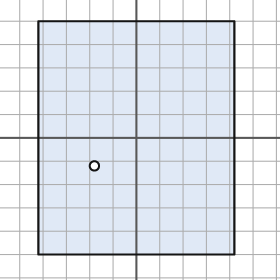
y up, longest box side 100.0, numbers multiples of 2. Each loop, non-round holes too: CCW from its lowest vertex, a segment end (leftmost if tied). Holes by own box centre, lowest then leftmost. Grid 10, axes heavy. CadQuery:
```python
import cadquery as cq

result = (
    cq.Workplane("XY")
    .moveTo(-42.0, -50.0)
    .lineTo(42.0, -50.0)
    .lineTo(42.0, 50.0)
    .lineTo(-42.0, 50.0)
    .close()
    .moveTo(-18.0, -12.0)
    .circle(2.0)
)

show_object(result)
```